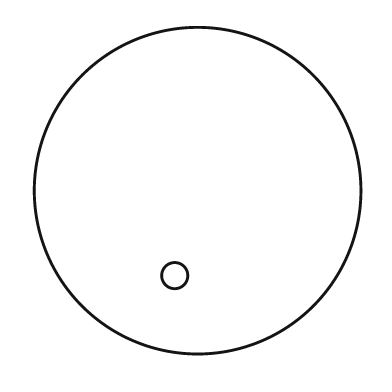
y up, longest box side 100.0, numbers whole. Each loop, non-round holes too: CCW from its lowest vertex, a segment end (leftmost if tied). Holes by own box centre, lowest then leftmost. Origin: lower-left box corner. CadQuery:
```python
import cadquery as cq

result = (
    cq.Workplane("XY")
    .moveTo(50.0, 50.0)
    .circle(50.0)
    .moveTo(43.0, 24.0)
    .circle(4.0)
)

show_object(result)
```